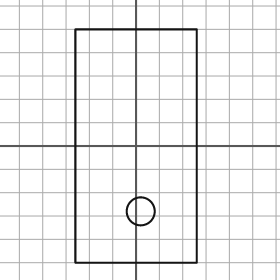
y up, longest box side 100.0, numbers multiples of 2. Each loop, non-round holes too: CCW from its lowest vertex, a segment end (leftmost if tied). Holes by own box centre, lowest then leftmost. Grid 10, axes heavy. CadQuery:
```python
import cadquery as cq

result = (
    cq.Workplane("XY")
    .moveTo(-26.0, -50.0)
    .lineTo(26.0, -50.0)
    .lineTo(26.0, 50.0)
    .lineTo(-26.0, 50.0)
    .close()
    .moveTo(2.0, -28.0)
    .circle(6.0)
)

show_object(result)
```